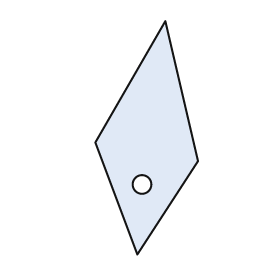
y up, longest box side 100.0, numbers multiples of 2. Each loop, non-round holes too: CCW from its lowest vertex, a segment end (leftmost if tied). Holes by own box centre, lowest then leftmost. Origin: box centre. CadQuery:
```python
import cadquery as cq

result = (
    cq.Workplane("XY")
    .moveTo(-4.0, -50.0)
    .lineTo(22.0, -10.0)
    .lineTo(8.0, 50.0)
    .lineTo(-22.0, -2.0)
    .close()
    .moveTo(-2.0, -20.0)
    .circle(4.0)
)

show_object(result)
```